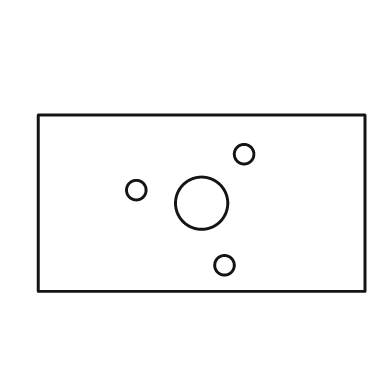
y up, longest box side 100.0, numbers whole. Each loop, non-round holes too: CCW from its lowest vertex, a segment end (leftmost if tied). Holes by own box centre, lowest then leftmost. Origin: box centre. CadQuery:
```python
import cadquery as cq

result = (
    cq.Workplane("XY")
    .moveTo(-50.0, -27.0)
    .lineTo(50.0, -27.0)
    .lineTo(50.0, 27.0)
    .lineTo(-50.0, 27.0)
    .close()
    .moveTo(7.0, -19.0)
    .circle(3.0)
    .moveTo(0.0, 0.0)
    .circle(8.0)
    .moveTo(-20.0, 4.0)
    .circle(3.0)
    .moveTo(13.0, 15.0)
    .circle(3.0)
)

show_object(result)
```